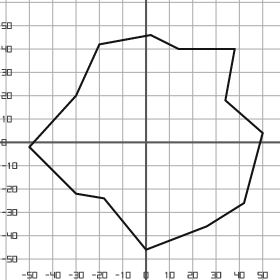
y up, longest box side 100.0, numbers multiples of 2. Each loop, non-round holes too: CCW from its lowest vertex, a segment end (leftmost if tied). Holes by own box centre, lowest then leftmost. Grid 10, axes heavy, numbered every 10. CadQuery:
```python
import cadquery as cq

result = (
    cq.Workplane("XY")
    .moveTo(0.0, -46.0)
    .lineTo(26.0, -36.0)
    .lineTo(42.0, -26.0)
    .lineTo(50.0, 4.0)
    .lineTo(34.0, 18.0)
    .lineTo(38.0, 40.0)
    .lineTo(14.0, 40.0)
    .lineTo(2.0, 46.0)
    .lineTo(-20.0, 42.0)
    .lineTo(-30.0, 20.0)
    .lineTo(-50.0, -2.0)
    .lineTo(-30.0, -22.0)
    .lineTo(-18.0, -24.0)
    .close()
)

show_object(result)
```